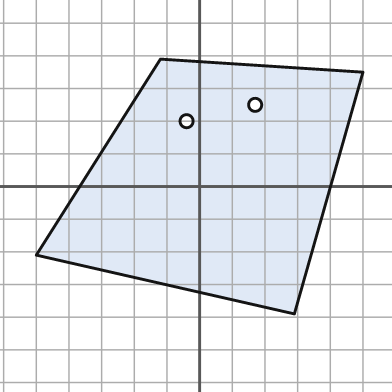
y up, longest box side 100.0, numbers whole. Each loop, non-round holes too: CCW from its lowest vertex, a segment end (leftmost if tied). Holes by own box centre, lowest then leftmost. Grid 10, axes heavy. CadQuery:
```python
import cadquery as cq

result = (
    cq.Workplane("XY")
    .moveTo(29.0, -39.0)
    .lineTo(50.0, 35.0)
    .lineTo(-12.0, 39.0)
    .lineTo(-50.0, -21.0)
    .close()
    .moveTo(-4.0, 20.0)
    .circle(2.0)
    .moveTo(17.0, 25.0)
    .circle(2.0)
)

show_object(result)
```